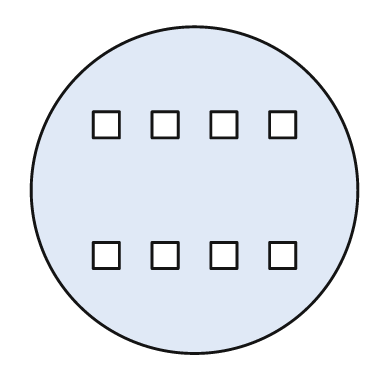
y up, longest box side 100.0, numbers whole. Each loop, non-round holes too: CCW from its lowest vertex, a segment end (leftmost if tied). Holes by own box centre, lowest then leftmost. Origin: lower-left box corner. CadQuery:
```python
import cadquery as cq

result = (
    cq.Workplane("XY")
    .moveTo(50.0, 50.0)
    .circle(50.0)
    .moveTo(19.0, 26.0)
    .lineTo(27.0, 26.0)
    .lineTo(27.0, 34.0)
    .lineTo(19.0, 34.0)
    .close()
    .moveTo(37.0, 26.0)
    .lineTo(45.0, 26.0)
    .lineTo(45.0, 34.0)
    .lineTo(37.0, 34.0)
    .close()
    .moveTo(55.0, 26.0)
    .lineTo(63.0, 26.0)
    .lineTo(63.0, 34.0)
    .lineTo(55.0, 34.0)
    .close()
    .moveTo(73.0, 26.0)
    .lineTo(81.0, 26.0)
    .lineTo(81.0, 34.0)
    .lineTo(73.0, 34.0)
    .close()
    .moveTo(19.0, 66.0)
    .lineTo(27.0, 66.0)
    .lineTo(27.0, 74.0)
    .lineTo(19.0, 74.0)
    .close()
    .moveTo(37.0, 66.0)
    .lineTo(45.0, 66.0)
    .lineTo(45.0, 74.0)
    .lineTo(37.0, 74.0)
    .close()
    .moveTo(55.0, 66.0)
    .lineTo(63.0, 66.0)
    .lineTo(63.0, 74.0)
    .lineTo(55.0, 74.0)
    .close()
    .moveTo(73.0, 66.0)
    .lineTo(81.0, 66.0)
    .lineTo(81.0, 74.0)
    .lineTo(73.0, 74.0)
    .close()
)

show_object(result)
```